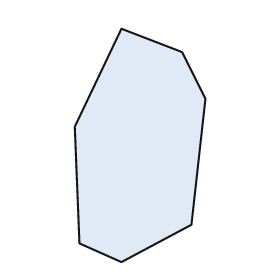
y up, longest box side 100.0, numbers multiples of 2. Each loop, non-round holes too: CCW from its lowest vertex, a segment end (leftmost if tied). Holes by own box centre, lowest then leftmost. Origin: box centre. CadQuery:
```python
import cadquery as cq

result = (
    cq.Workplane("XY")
    .moveTo(-8.0, -50.0)
    .lineTo(22.0, -34.0)
    .lineTo(28.0, 20.0)
    .lineTo(18.0, 40.0)
    .lineTo(-8.0, 50.0)
    .lineTo(-28.0, 8.0)
    .lineTo(-26.0, -42.0)
    .close()
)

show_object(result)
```